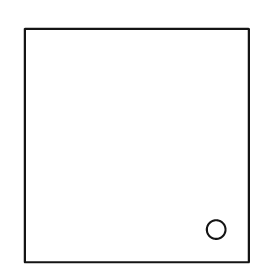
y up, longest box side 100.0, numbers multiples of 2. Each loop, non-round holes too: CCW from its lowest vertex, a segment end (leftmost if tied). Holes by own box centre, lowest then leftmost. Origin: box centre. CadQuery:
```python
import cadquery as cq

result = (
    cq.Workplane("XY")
    .moveTo(-48.0, -50.0)
    .lineTo(48.0, -50.0)
    .lineTo(48.0, 50.0)
    .lineTo(-48.0, 50.0)
    .close()
    .moveTo(34.0, -36.0)
    .circle(4.0)
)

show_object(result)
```